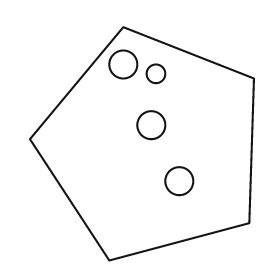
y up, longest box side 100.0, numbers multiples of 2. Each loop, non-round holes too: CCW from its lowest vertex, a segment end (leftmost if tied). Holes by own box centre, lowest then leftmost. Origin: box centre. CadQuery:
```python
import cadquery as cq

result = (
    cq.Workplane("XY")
    .moveTo(-14.0, -50.0)
    .lineTo(46.0, -34.0)
    .lineTo(48.0, 28.0)
    .lineTo(-8.0, 50.0)
    .lineTo(-48.0, 2.0)
    .close()
    .moveTo(16.0, -16.0)
    .circle(6.0)
    .moveTo(4.0, 8.0)
    .circle(6.0)
    .moveTo(6.0, 30.0)
    .circle(4.0)
    .moveTo(-8.0, 34.0)
    .circle(6.0)
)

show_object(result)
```